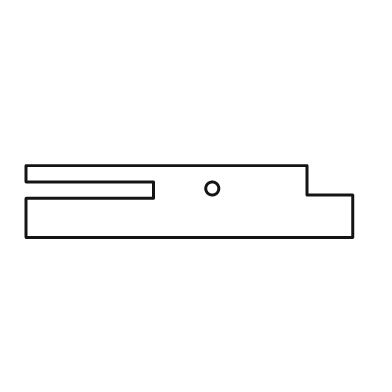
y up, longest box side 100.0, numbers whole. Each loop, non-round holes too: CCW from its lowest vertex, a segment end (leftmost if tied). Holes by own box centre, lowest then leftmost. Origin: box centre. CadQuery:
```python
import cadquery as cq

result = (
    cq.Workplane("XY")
    .moveTo(-50.0, -11.0)
    .lineTo(50.0, -11.0)
    .lineTo(50.0, 2.0)
    .lineTo(36.0, 2.0)
    .lineTo(36.0, 11.0)
    .lineTo(-50.0, 11.0)
    .lineTo(-50.0, 6.0)
    .lineTo(-11.0, 6.0)
    .lineTo(-11.0, 1.0)
    .lineTo(-50.0, 1.0)
    .close()
    .moveTo(7.0, 4.0)
    .circle(2.0)
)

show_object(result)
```